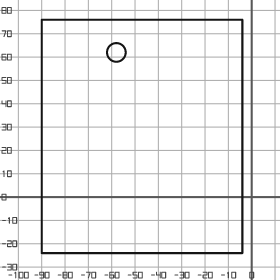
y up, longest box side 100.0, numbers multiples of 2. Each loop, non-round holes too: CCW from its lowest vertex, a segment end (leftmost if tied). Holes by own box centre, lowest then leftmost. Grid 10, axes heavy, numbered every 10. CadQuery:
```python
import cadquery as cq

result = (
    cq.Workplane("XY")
    .moveTo(-90.0, -24.0)
    .lineTo(-4.0, -24.0)
    .lineTo(-4.0, 76.0)
    .lineTo(-90.0, 76.0)
    .close()
    .moveTo(-58.0, 62.0)
    .circle(4.0)
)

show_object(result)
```